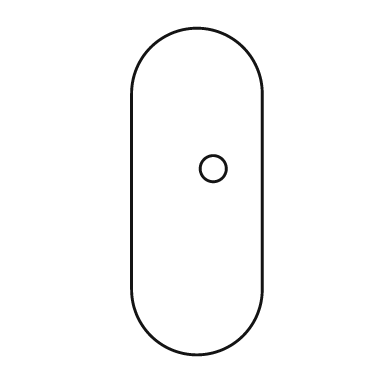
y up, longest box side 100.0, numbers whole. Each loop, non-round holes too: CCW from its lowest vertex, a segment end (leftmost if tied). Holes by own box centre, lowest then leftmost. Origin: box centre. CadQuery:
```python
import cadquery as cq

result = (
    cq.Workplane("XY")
    .moveTo(-20.0, -30.0)
    .threePointArc((0.0, -50.0), (20.0, -30.0))
    .lineTo(20.0, 30.0)
    .threePointArc((0.0, 50.0), (-20.0, 30.0))
    .close()
    .moveTo(5.0, 7.0)
    .circle(4.0)
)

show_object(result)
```